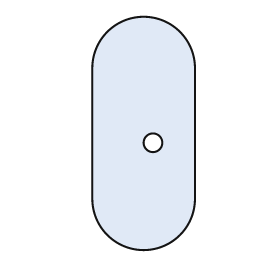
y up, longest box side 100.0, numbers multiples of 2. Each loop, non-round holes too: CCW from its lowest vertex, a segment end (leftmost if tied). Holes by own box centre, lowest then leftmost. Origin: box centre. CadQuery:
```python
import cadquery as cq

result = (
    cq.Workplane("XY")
    .moveTo(-22.0, -28.0)
    .threePointArc((0.0, -50.0), (22.0, -28.0))
    .lineTo(22.0, 28.0)
    .threePointArc((0.0, 50.0), (-22.0, 28.0))
    .close()
    .moveTo(4.0, -4.0)
    .circle(4.0)
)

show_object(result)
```